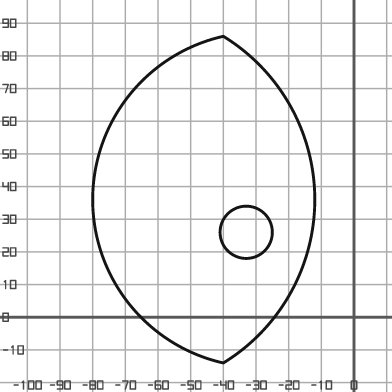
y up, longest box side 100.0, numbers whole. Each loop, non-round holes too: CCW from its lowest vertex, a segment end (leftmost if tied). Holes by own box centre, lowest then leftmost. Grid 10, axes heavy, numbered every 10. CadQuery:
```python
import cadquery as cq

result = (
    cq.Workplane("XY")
    .moveTo(-40.0, -14.0)
    .threePointArc((-12.0, 36.0), (-40.0, 86.0))
    .threePointArc((-80.0, 36.0), (-40.0, -14.0))
    .close()
    .moveTo(-33.0, 26.0)
    .circle(8.0)
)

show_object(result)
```